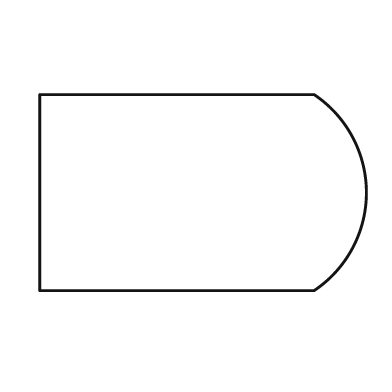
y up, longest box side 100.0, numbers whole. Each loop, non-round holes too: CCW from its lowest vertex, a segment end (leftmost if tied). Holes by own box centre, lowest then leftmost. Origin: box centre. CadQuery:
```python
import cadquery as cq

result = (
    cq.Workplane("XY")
    .moveTo(-50.0, -30.0)
    .lineTo(34.0, -30.0)
    .threePointArc((50.0, 0.0), (34.0, 30.0))
    .lineTo(-50.0, 30.0)
    .close()
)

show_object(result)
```